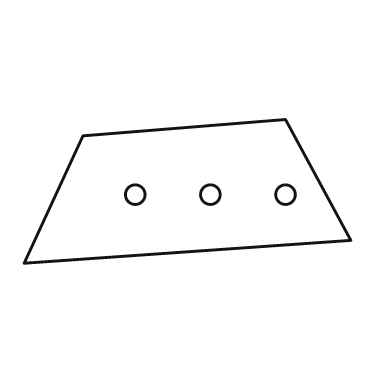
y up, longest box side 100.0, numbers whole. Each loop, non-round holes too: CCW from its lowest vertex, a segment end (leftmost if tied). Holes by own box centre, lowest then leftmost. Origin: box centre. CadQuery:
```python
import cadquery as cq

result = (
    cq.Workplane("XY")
    .moveTo(-50.0, -22.0)
    .lineTo(50.0, -15.0)
    .lineTo(30.0, 22.0)
    .lineTo(-32.0, 17.0)
    .close()
    .moveTo(-16.0, -1.0)
    .circle(3.0)
    .moveTo(7.0, -1.0)
    .circle(3.0)
    .moveTo(30.0, -1.0)
    .circle(3.0)
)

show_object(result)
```